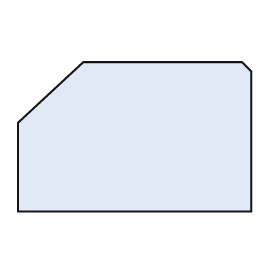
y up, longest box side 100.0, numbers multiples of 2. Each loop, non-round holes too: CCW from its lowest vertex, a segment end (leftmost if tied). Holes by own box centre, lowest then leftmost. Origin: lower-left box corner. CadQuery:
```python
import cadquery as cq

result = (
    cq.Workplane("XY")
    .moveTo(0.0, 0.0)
    .lineTo(100.0, 0.0)
    .lineTo(100.0, 60.0)
    .lineTo(96.0, 64.0)
    .lineTo(28.0, 64.0)
    .lineTo(0.0, 38.0)
    .close()
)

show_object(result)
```